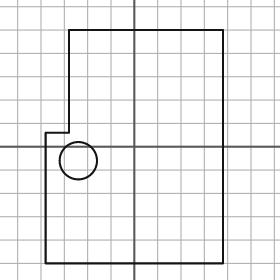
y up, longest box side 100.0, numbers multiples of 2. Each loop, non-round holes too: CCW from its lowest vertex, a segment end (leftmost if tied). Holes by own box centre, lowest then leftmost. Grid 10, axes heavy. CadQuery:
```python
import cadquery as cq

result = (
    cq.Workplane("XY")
    .moveTo(-38.0, -50.0)
    .lineTo(38.0, -50.0)
    .lineTo(38.0, 50.0)
    .lineTo(-28.0, 50.0)
    .lineTo(-28.0, 6.0)
    .lineTo(-38.0, 6.0)
    .close()
    .moveTo(-24.0, -6.0)
    .circle(8.0)
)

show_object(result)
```